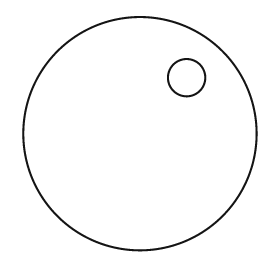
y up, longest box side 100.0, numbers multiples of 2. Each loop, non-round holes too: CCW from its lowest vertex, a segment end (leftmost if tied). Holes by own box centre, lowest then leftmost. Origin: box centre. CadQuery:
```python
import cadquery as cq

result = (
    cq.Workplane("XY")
    .moveTo(0.0, 0.0)
    .circle(50.0)
    .moveTo(20.0, 24.0)
    .circle(8.0)
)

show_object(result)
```